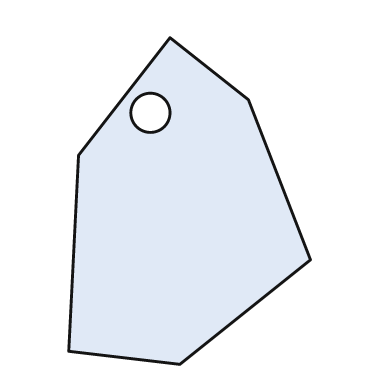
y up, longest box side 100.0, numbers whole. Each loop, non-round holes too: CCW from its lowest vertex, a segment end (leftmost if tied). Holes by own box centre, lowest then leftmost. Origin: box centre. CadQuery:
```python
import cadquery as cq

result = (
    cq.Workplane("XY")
    .moveTo(-3.0, -50.0)
    .lineTo(37.0, -18.0)
    .lineTo(18.0, 31.0)
    .lineTo(-6.0, 50.0)
    .lineTo(-34.0, 14.0)
    .lineTo(-37.0, -46.0)
    .close()
    .moveTo(-12.0, 27.0)
    .circle(6.0)
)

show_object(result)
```